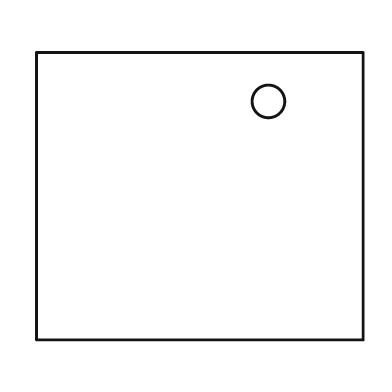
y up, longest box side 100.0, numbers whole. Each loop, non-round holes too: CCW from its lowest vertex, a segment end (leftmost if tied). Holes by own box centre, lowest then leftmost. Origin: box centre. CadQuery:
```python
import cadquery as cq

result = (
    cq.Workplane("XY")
    .moveTo(-50.0, -44.0)
    .lineTo(50.0, -44.0)
    .lineTo(50.0, 44.0)
    .lineTo(-50.0, 44.0)
    .close()
    .moveTo(21.0, 29.0)
    .circle(5.0)
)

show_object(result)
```